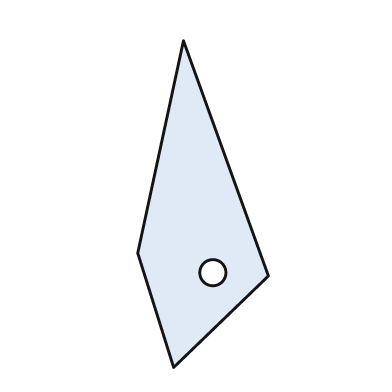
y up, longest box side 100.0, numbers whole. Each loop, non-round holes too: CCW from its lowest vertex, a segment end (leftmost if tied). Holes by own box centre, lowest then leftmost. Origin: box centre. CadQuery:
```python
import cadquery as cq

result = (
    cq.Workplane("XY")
    .moveTo(-9.0, -50.0)
    .lineTo(20.0, -22.0)
    .lineTo(-6.0, 50.0)
    .lineTo(-20.0, -15.0)
    .close()
    .moveTo(3.0, -21.0)
    .circle(4.0)
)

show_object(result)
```